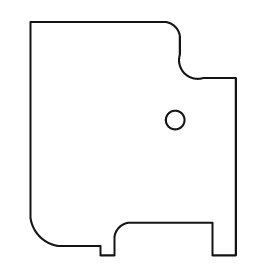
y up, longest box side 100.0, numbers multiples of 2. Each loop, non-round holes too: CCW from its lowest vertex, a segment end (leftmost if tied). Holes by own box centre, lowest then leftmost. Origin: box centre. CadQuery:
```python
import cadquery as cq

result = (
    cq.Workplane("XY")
    .moveTo(-14.0, -50.0)
    .lineTo(-8.0, -50.0)
    .lineTo(-8.0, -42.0)
    .threePointArc((-6.0, -38.0), (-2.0, -36.0))
    .lineTo(34.0, -36.0)
    .lineTo(34.0, -50.0)
    .lineTo(44.0, -50.0)
    .lineTo(44.0, 26.0)
    .lineTo(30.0, 26.0)
    .threePointArc((22.0, 28.0), (20.0, 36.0))
    .lineTo(20.0, 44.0)
    .threePointArc((18.0, 48.0), (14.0, 50.0))
    .lineTo(-44.0, 50.0)
    .lineTo(-44.0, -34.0)
    .threePointArc((-40.0, -42.0), (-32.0, -46.0))
    .lineTo(-14.0, -46.0)
    .close()
    .moveTo(18.0, 8.0)
    .circle(4.0)
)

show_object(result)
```